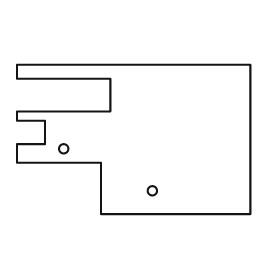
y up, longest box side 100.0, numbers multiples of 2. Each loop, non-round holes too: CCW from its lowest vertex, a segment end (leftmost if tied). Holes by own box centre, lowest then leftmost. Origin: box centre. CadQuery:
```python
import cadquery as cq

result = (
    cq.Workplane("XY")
    .moveTo(-14.0, -32.0)
    .lineTo(50.0, -32.0)
    .lineTo(50.0, 32.0)
    .lineTo(-50.0, 32.0)
    .lineTo(-50.0, 26.0)
    .lineTo(-10.0, 26.0)
    .lineTo(-10.0, 12.0)
    .lineTo(-50.0, 12.0)
    .lineTo(-50.0, 8.0)
    .lineTo(-38.0, 8.0)
    .lineTo(-38.0, -2.0)
    .lineTo(-50.0, -2.0)
    .lineTo(-50.0, -10.0)
    .lineTo(-14.0, -10.0)
    .close()
    .moveTo(8.0, -22.0)
    .circle(2.0)
    .moveTo(-30.0, -4.0)
    .circle(2.0)
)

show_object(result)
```